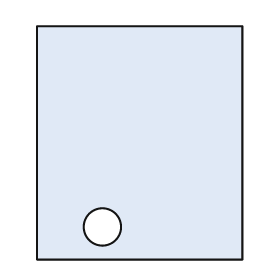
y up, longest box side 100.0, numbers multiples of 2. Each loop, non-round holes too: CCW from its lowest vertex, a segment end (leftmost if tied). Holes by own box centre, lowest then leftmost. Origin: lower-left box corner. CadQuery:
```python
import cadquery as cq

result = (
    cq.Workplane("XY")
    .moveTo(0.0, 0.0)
    .lineTo(88.0, 0.0)
    .lineTo(88.0, 100.0)
    .lineTo(0.0, 100.0)
    .close()
    .moveTo(28.0, 14.0)
    .circle(8.0)
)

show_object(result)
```